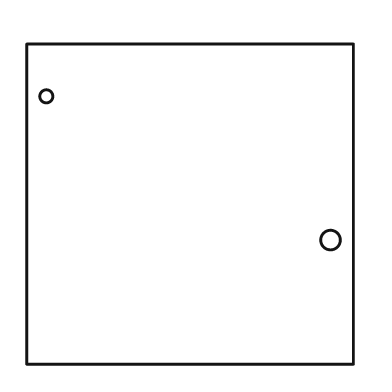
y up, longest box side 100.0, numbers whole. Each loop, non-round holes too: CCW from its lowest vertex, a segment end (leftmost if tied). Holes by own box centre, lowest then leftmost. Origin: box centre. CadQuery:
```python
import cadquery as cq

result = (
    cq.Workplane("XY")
    .moveTo(-50.0, -49.0)
    .lineTo(50.0, -49.0)
    .lineTo(50.0, 49.0)
    .lineTo(-50.0, 49.0)
    .close()
    .moveTo(43.0, -11.0)
    .circle(3.0)
    .moveTo(-44.0, 33.0)
    .circle(2.0)
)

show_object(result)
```